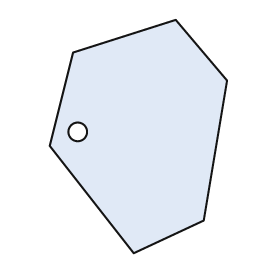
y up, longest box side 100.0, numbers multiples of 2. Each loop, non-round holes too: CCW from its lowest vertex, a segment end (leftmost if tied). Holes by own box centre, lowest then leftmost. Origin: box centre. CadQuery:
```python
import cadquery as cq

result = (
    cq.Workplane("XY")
    .moveTo(-2.0, -50.0)
    .lineTo(28.0, -36.0)
    .lineTo(38.0, 24.0)
    .lineTo(16.0, 50.0)
    .lineTo(-28.0, 36.0)
    .lineTo(-38.0, -4.0)
    .close()
    .moveTo(-26.0, 2.0)
    .circle(4.0)
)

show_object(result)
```